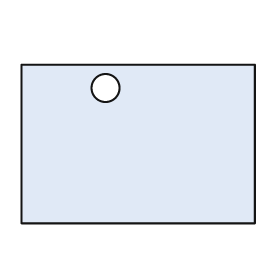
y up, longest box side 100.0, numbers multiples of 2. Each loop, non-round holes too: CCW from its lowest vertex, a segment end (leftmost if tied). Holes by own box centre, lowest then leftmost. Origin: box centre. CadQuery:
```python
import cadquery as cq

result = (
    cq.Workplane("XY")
    .moveTo(-50.0, -34.0)
    .lineTo(50.0, -34.0)
    .lineTo(50.0, 34.0)
    .lineTo(-50.0, 34.0)
    .close()
    .moveTo(-14.0, 24.0)
    .circle(6.0)
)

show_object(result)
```